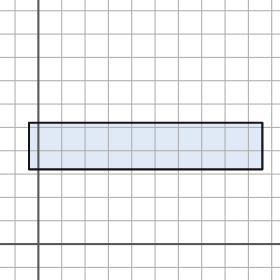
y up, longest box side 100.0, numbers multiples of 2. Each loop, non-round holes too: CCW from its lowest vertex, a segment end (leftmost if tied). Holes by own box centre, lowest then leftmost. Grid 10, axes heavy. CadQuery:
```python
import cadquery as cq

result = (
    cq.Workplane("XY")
    .moveTo(-4.0, 32.0)
    .lineTo(96.0, 32.0)
    .lineTo(96.0, 52.0)
    .lineTo(-4.0, 52.0)
    .close()
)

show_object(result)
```